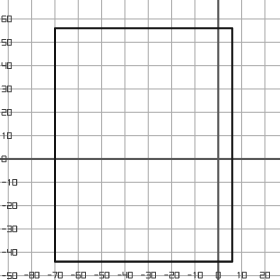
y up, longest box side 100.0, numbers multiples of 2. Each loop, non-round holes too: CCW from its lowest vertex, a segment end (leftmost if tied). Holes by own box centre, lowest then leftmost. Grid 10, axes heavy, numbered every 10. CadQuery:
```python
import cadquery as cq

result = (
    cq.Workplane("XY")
    .moveTo(-70.0, -44.0)
    .lineTo(6.0, -44.0)
    .lineTo(6.0, 56.0)
    .lineTo(-70.0, 56.0)
    .close()
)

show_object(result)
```